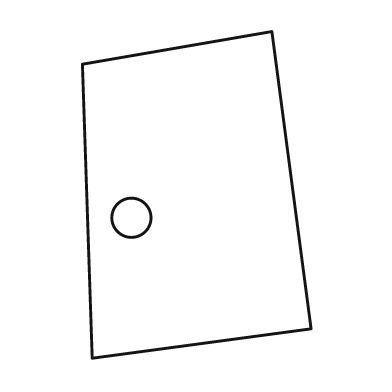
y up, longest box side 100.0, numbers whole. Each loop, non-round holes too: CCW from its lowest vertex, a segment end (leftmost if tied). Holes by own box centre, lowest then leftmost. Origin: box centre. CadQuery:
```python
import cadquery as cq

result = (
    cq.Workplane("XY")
    .moveTo(-32.0, -50.0)
    .lineTo(35.0, -41.0)
    .lineTo(23.0, 50.0)
    .lineTo(-35.0, 40.0)
    .close()
    .moveTo(-20.0, -7.0)
    .circle(6.0)
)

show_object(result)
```